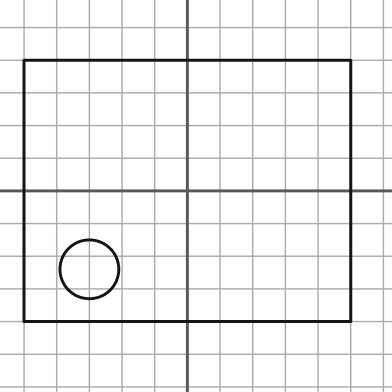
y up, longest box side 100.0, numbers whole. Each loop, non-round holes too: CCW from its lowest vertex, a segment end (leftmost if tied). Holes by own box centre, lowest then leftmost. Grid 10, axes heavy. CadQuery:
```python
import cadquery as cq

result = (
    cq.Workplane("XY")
    .moveTo(-50.0, -40.0)
    .lineTo(50.0, -40.0)
    .lineTo(50.0, 40.0)
    .lineTo(-50.0, 40.0)
    .close()
    .moveTo(-30.0, -24.0)
    .circle(9.0)
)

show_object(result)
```